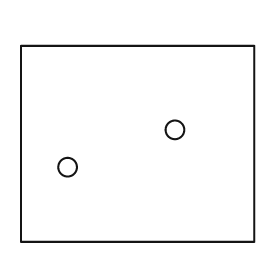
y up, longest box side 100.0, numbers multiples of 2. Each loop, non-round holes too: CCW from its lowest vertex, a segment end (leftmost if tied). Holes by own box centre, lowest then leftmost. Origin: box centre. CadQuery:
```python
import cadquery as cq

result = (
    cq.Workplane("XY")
    .moveTo(-50.0, -42.0)
    .lineTo(50.0, -42.0)
    .lineTo(50.0, 42.0)
    .lineTo(-50.0, 42.0)
    .close()
    .moveTo(-30.0, -10.0)
    .circle(4.0)
    .moveTo(16.0, 6.0)
    .circle(4.0)
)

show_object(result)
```